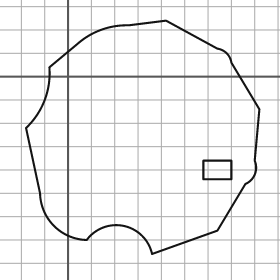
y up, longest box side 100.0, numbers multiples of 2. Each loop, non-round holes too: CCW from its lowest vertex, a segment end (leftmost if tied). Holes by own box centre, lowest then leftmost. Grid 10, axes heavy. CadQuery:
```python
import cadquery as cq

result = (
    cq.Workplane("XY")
    .moveTo(36.0, -76.0)
    .lineTo(64.0, -66.0)
    .lineTo(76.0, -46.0)
    .threePointArc((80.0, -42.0), (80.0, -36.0))
    .lineTo(82.0, -14.0)
    .lineTo(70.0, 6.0)
    .threePointArc((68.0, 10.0), (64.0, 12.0))
    .lineTo(42.0, 24.0)
    .lineTo(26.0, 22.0)
    .threePointArc((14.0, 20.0), (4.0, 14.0))
    .lineTo(-8.0, 4.0)
    .threePointArc((-10.0, -10.0), (-18.0, -22.0))
    .lineTo(-12.0, -50.0)
    .threePointArc((-6.0, -64.0), (8.0, -70.0))
    .threePointArc((24.0, -64.0), (36.0, -76.0))
    .close()
    .moveTo(58.0, -44.0)
    .lineTo(70.0, -44.0)
    .lineTo(70.0, -36.0)
    .lineTo(58.0, -36.0)
    .close()
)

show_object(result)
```